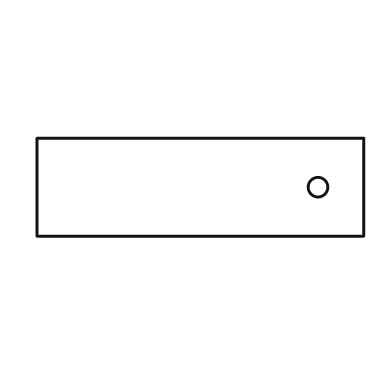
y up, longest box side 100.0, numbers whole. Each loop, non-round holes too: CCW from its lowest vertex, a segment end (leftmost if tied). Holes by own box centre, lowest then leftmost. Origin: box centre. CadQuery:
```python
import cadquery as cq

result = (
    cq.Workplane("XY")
    .moveTo(-50.0, -15.0)
    .lineTo(50.0, -15.0)
    .lineTo(50.0, 15.0)
    .lineTo(-50.0, 15.0)
    .close()
    .moveTo(36.0, 0.0)
    .circle(3.0)
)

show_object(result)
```